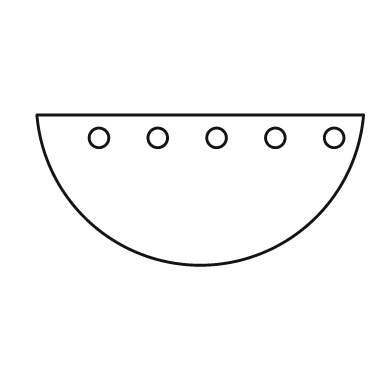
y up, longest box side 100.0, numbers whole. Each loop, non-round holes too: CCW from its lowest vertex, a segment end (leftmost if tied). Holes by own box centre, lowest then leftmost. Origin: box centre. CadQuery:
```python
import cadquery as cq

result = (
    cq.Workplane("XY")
    .moveTo(-50.0, 23.0)
    .threePointArc((0.0, -23.0), (50.0, 23.0))
    .close()
    .moveTo(-31.0, 16.0)
    .circle(3.0)
    .moveTo(-13.0, 16.0)
    .circle(3.0)
    .moveTo(5.0, 16.0)
    .circle(3.0)
    .moveTo(23.0, 16.0)
    .circle(3.0)
    .moveTo(41.0, 16.0)
    .circle(3.0)
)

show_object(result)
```